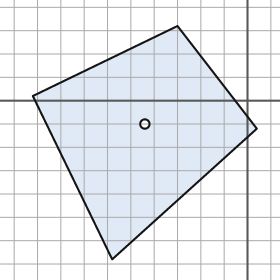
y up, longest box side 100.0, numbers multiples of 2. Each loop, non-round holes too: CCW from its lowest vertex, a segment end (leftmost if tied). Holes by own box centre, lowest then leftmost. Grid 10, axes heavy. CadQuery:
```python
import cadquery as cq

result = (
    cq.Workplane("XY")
    .moveTo(-58.0, -68.0)
    .lineTo(4.0, -12.0)
    .lineTo(-30.0, 32.0)
    .lineTo(-92.0, 2.0)
    .close()
    .moveTo(-44.0, -10.0)
    .circle(2.0)
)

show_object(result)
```